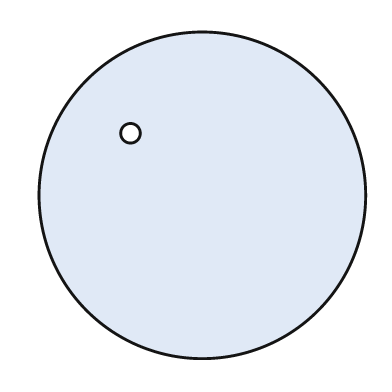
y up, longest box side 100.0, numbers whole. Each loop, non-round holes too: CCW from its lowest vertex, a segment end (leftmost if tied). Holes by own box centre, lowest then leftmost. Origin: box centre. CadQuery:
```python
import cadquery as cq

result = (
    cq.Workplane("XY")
    .moveTo(0.0, 0.0)
    .circle(50.0)
    .moveTo(-22.0, 19.0)
    .circle(3.0)
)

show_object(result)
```